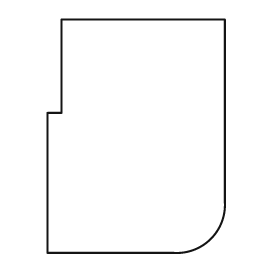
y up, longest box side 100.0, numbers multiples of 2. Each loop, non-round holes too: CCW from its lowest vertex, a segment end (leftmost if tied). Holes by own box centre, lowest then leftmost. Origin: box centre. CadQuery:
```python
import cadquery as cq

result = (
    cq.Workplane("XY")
    .moveTo(-38.0, -50.0)
    .lineTo(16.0, -50.0)
    .threePointArc((32.0, -44.0), (38.0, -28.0))
    .lineTo(38.0, 50.0)
    .lineTo(-32.0, 50.0)
    .lineTo(-32.0, 10.0)
    .lineTo(-38.0, 10.0)
    .close()
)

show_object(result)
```